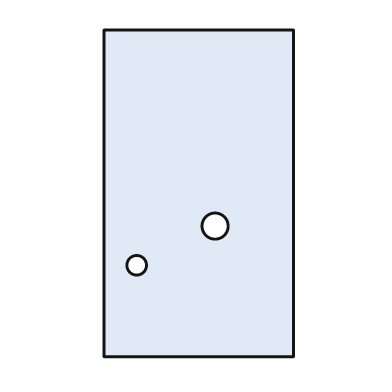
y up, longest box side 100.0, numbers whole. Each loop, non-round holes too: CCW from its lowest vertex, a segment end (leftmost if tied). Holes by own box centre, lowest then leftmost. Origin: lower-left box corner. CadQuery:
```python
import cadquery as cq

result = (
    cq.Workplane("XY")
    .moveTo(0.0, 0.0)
    .lineTo(58.0, 0.0)
    .lineTo(58.0, 100.0)
    .lineTo(0.0, 100.0)
    .close()
    .moveTo(10.0, 28.0)
    .circle(3.0)
    .moveTo(34.0, 40.0)
    .circle(4.0)
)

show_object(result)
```